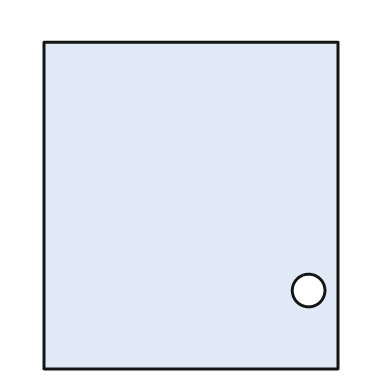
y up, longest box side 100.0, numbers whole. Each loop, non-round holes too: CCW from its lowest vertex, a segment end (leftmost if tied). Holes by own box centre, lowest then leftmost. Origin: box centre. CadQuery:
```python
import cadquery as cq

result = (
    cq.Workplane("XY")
    .moveTo(-45.0, -50.0)
    .lineTo(45.0, -50.0)
    .lineTo(45.0, 50.0)
    .lineTo(-45.0, 50.0)
    .close()
    .moveTo(36.0, -26.0)
    .circle(5.0)
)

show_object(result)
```